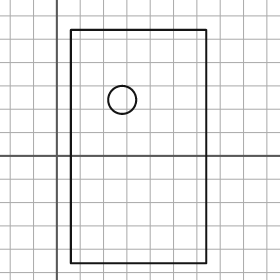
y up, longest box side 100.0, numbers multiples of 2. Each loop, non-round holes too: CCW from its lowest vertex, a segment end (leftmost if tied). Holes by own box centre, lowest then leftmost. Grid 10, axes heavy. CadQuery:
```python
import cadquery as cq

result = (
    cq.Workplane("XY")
    .moveTo(6.0, -46.0)
    .lineTo(64.0, -46.0)
    .lineTo(64.0, 54.0)
    .lineTo(6.0, 54.0)
    .close()
    .moveTo(28.0, 24.0)
    .circle(6.0)
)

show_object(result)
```